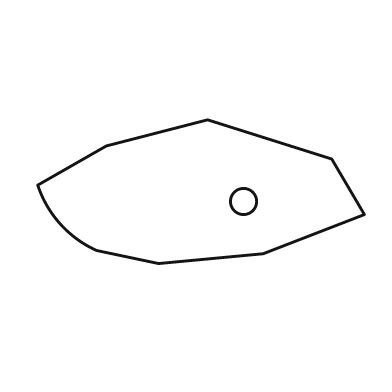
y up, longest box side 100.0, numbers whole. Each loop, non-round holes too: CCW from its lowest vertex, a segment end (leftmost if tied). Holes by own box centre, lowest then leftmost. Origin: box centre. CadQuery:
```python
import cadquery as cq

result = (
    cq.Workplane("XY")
    .moveTo(-13.0, -22.0)
    .lineTo(19.0, -19.0)
    .lineTo(50.0, -7.0)
    .lineTo(40.0, 10.0)
    .lineTo(2.0, 22.0)
    .lineTo(-29.0, 14.0)
    .lineTo(-50.0, 2.0)
    .threePointArc((-43.0, -10.0), (-32.0, -18.0))
    .close()
    .moveTo(13.0, -3.0)
    .circle(4.0)
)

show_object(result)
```